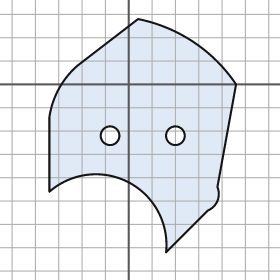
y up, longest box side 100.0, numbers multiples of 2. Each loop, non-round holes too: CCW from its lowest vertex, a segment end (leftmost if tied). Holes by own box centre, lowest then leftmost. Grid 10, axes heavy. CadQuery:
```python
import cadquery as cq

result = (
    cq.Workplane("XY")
    .moveTo(16.0, -72.0)
    .lineTo(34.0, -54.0)
    .threePointArc((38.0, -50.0), (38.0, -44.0))
    .lineTo(46.0, 0.0)
    .threePointArc((28.0, 18.0), (4.0, 28.0))
    .lineTo(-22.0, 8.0)
    .threePointArc((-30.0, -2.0), (-34.0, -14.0))
    .lineTo(-34.0, -46.0)
    .threePointArc((0.0, -42.0), (16.0, -72.0))
    .close()
    .moveTo(-8.0, -22.0)
    .circle(4.0)
    .moveTo(20.0, -22.0)
    .circle(4.0)
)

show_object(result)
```